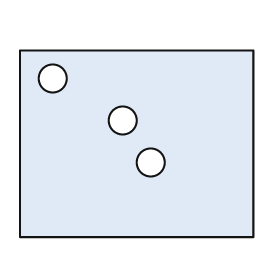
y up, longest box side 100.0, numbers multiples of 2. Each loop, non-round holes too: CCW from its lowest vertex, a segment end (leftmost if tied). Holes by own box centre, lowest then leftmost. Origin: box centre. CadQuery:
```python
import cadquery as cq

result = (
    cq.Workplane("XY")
    .moveTo(-50.0, -40.0)
    .lineTo(50.0, -40.0)
    .lineTo(50.0, 40.0)
    .lineTo(-50.0, 40.0)
    .close()
    .moveTo(6.0, -8.0)
    .circle(6.0)
    .moveTo(-6.0, 10.0)
    .circle(6.0)
    .moveTo(-36.0, 28.0)
    .circle(6.0)
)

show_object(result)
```